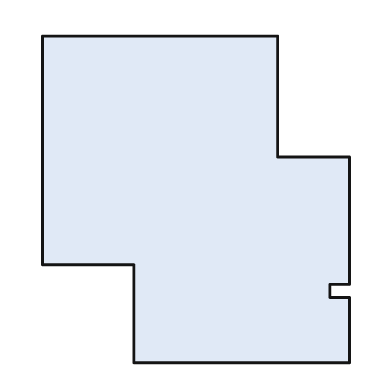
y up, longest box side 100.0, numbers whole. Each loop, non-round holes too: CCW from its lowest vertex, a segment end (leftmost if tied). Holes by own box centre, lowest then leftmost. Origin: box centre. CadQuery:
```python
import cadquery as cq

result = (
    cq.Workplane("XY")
    .moveTo(-19.0, -50.0)
    .lineTo(47.0, -50.0)
    .lineTo(47.0, -30.0)
    .lineTo(41.0, -30.0)
    .lineTo(41.0, -26.0)
    .lineTo(47.0, -26.0)
    .lineTo(47.0, 13.0)
    .lineTo(25.0, 13.0)
    .lineTo(25.0, 50.0)
    .lineTo(-47.0, 50.0)
    .lineTo(-47.0, -20.0)
    .lineTo(-19.0, -20.0)
    .close()
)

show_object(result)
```